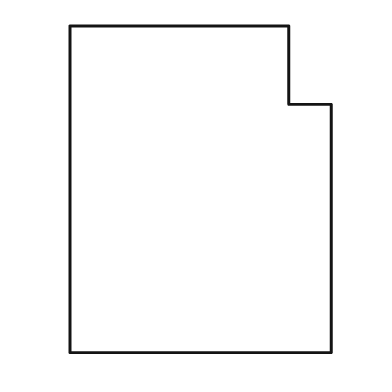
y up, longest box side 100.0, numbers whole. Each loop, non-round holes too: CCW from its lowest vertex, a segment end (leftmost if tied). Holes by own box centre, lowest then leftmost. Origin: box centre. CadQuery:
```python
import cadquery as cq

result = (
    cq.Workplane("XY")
    .moveTo(-40.0, -50.0)
    .lineTo(40.0, -50.0)
    .lineTo(40.0, 26.0)
    .lineTo(27.0, 26.0)
    .lineTo(27.0, 50.0)
    .lineTo(-40.0, 50.0)
    .close()
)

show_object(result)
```